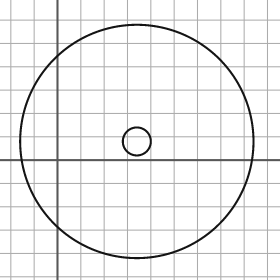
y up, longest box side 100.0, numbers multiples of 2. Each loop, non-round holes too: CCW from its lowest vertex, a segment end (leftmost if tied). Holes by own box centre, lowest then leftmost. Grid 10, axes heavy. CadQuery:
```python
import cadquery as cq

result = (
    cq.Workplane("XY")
    .moveTo(34.0, 8.0)
    .circle(50.0)
    .moveTo(34.0, 8.0)
    .circle(6.0)
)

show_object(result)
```